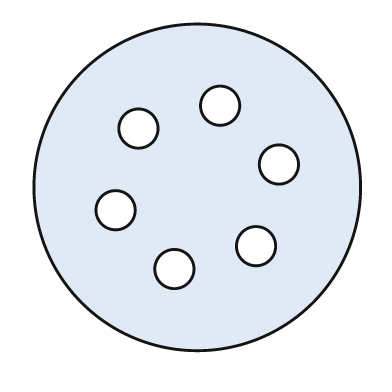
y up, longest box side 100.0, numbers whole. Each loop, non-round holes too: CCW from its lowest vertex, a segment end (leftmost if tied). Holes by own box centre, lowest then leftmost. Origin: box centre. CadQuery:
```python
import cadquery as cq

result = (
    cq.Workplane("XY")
    .moveTo(0.0, 0.0)
    .circle(50.0)
    .moveTo(-7.0, -25.0)
    .circle(6.0)
    .moveTo(18.0, -18.0)
    .circle(6.0)
    .moveTo(-25.0, -7.0)
    .circle(6.0)
    .moveTo(25.0, 7.0)
    .circle(6.0)
    .moveTo(-18.0, 18.0)
    .circle(6.0)
    .moveTo(7.0, 25.0)
    .circle(6.0)
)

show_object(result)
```